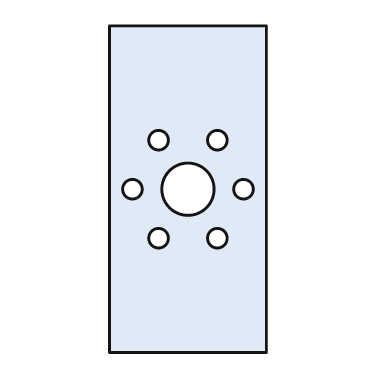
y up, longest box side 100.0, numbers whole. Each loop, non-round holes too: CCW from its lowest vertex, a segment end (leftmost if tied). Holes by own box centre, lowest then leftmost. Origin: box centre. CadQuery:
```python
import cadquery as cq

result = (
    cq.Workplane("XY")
    .moveTo(-24.0, -50.0)
    .lineTo(24.0, -50.0)
    .lineTo(24.0, 50.0)
    .lineTo(-24.0, 50.0)
    .close()
    .moveTo(-9.0, -15.0)
    .circle(3.0)
    .moveTo(9.0, -15.0)
    .circle(3.0)
    .moveTo(-17.0, 0.0)
    .circle(3.0)
    .moveTo(0.0, 0.0)
    .circle(8.0)
    .moveTo(17.0, 0.0)
    .circle(3.0)
    .moveTo(-9.0, 15.0)
    .circle(3.0)
    .moveTo(9.0, 15.0)
    .circle(3.0)
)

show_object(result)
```